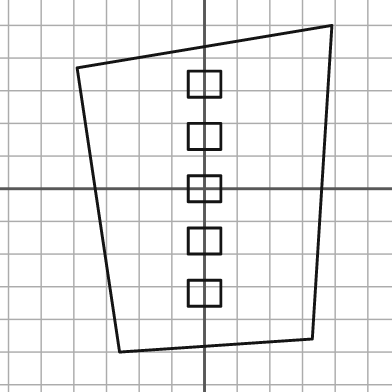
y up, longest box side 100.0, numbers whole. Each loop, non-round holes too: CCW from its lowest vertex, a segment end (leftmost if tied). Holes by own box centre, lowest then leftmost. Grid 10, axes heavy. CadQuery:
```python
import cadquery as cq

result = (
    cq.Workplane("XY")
    .moveTo(-26.0, -50.0)
    .lineTo(33.0, -46.0)
    .lineTo(39.0, 50.0)
    .lineTo(-39.0, 37.0)
    .close()
    .moveTo(-5.0, -36.0)
    .lineTo(5.0, -36.0)
    .lineTo(5.0, -28.0)
    .lineTo(-5.0, -28.0)
    .close()
    .moveTo(-5.0, -20.0)
    .lineTo(5.0, -20.0)
    .lineTo(5.0, -12.0)
    .lineTo(-5.0, -12.0)
    .close()
    .moveTo(-5.0, -4.0)
    .lineTo(5.0, -4.0)
    .lineTo(5.0, 4.0)
    .lineTo(-5.0, 4.0)
    .close()
    .moveTo(-5.0, 12.0)
    .lineTo(5.0, 12.0)
    .lineTo(5.0, 20.0)
    .lineTo(-5.0, 20.0)
    .close()
    .moveTo(-5.0, 28.0)
    .lineTo(5.0, 28.0)
    .lineTo(5.0, 36.0)
    .lineTo(-5.0, 36.0)
    .close()
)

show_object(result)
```